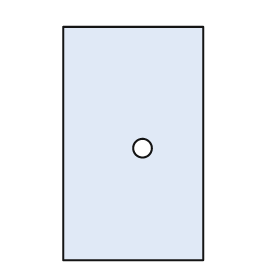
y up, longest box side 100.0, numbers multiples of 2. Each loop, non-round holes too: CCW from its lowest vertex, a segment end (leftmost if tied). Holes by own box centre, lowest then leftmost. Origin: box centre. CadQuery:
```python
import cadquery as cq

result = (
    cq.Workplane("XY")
    .moveTo(-30.0, -50.0)
    .lineTo(30.0, -50.0)
    .lineTo(30.0, 50.0)
    .lineTo(-30.0, 50.0)
    .close()
    .moveTo(4.0, -2.0)
    .circle(4.0)
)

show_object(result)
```